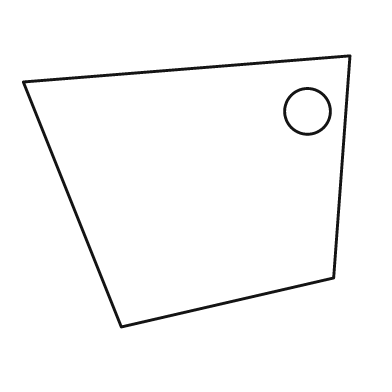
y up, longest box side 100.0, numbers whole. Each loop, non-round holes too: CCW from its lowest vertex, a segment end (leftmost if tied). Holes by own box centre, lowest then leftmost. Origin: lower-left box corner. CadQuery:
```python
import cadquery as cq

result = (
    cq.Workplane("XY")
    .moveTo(30.0, 0.0)
    .lineTo(95.0, 15.0)
    .lineTo(100.0, 83.0)
    .lineTo(0.0, 75.0)
    .close()
    .moveTo(87.0, 66.0)
    .circle(7.0)
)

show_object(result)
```